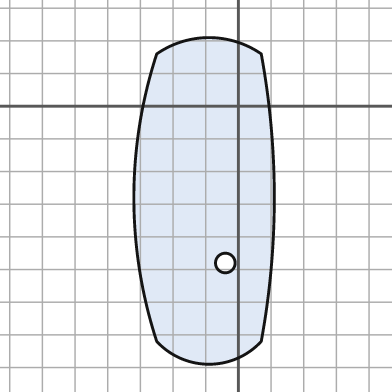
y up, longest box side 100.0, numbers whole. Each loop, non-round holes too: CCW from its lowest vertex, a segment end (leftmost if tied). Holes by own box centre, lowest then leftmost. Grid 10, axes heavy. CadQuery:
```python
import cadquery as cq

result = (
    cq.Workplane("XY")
    .moveTo(-25.0, -72.0)
    .threePointArc((-9.0, -79.0), (7.0, -72.0))
    .threePointArc((11.0, -28.0), (7.0, 16.0))
    .threePointArc((-9.0, 21.0), (-25.0, 16.0))
    .threePointArc((-32.0, -28.0), (-25.0, -72.0))
    .close()
    .moveTo(-4.0, -48.0)
    .circle(3.0)
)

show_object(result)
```